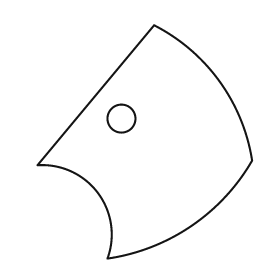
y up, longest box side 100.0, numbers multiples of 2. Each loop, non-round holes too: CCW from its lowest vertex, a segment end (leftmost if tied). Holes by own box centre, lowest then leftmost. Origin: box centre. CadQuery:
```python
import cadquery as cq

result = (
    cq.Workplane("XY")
    .moveTo(-16.0, -50.0)
    .threePointArc((20.0, -36.0), (46.0, -8.0))
    .threePointArc((32.0, 26.0), (4.0, 50.0))
    .lineTo(-46.0, -10.0)
    .threePointArc((-20.0, -22.0), (-16.0, -50.0))
    .close()
    .moveTo(-10.0, 10.0)
    .circle(6.0)
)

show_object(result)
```